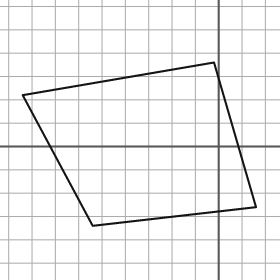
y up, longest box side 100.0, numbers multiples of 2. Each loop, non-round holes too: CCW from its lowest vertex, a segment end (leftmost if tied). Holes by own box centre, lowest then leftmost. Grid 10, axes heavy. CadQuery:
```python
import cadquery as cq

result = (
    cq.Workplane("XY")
    .moveTo(-54.0, -34.0)
    .lineTo(16.0, -26.0)
    .lineTo(-2.0, 36.0)
    .lineTo(-84.0, 22.0)
    .close()
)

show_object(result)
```